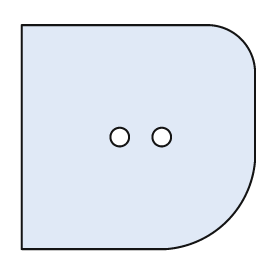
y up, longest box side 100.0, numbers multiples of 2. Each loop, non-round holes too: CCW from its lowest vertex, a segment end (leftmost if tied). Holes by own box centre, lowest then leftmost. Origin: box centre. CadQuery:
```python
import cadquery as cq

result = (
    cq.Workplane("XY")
    .moveTo(-50.0, -48.0)
    .lineTo(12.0, -48.0)
    .threePointArc((38.0, -36.0), (50.0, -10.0))
    .lineTo(50.0, 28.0)
    .threePointArc((44.0, 42.0), (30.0, 48.0))
    .lineTo(-50.0, 48.0)
    .close()
    .moveTo(-8.0, 0.0)
    .circle(4.0)
    .moveTo(10.0, 0.0)
    .circle(4.0)
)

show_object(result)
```